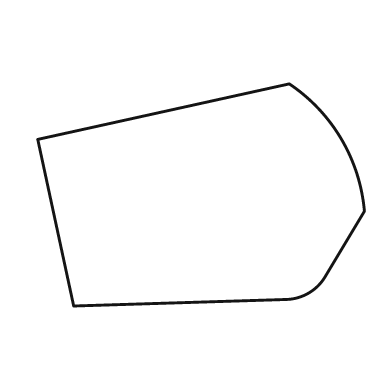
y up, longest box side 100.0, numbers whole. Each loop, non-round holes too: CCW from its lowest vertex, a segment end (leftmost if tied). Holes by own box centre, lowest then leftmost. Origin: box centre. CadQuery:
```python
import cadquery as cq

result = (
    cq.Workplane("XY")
    .moveTo(-39.0, -34.0)
    .lineTo(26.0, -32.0)
    .threePointArc((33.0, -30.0), (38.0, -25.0))
    .lineTo(50.0, -5.0)
    .threePointArc((43.0, 17.0), (27.0, 34.0))
    .lineTo(-50.0, 17.0)
    .close()
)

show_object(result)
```